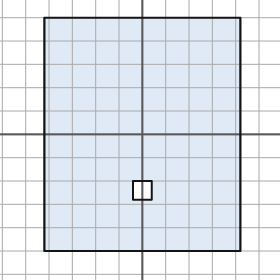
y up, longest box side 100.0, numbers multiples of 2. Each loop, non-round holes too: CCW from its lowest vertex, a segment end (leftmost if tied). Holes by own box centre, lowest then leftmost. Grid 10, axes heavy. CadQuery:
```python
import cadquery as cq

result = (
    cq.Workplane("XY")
    .moveTo(-42.0, -50.0)
    .lineTo(42.0, -50.0)
    .lineTo(42.0, 50.0)
    .lineTo(-42.0, 50.0)
    .close()
    .moveTo(-4.0, -28.0)
    .lineTo(4.0, -28.0)
    .lineTo(4.0, -20.0)
    .lineTo(-4.0, -20.0)
    .close()
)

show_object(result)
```